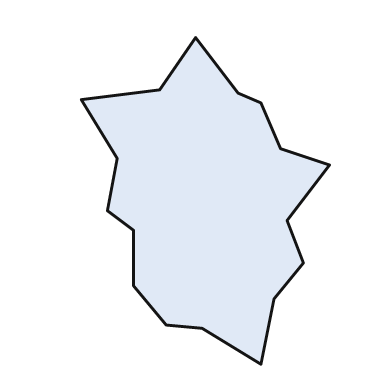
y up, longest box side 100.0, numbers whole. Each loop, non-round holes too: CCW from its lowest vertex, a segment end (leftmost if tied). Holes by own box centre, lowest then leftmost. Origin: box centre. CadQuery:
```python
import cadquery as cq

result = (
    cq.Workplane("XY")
    .moveTo(17.0, -50.0)
    .lineTo(21.0, -30.0)
    .lineTo(30.0, -19.0)
    .lineTo(25.0, -6.0)
    .lineTo(38.0, 11.0)
    .lineTo(23.0, 16.0)
    .lineTo(17.0, 30.0)
    .lineTo(10.0, 33.0)
    .lineTo(-3.0, 50.0)
    .lineTo(-14.0, 34.0)
    .lineTo(-38.0, 31.0)
    .lineTo(-27.0, 13.0)
    .lineTo(-30.0, -3.0)
    .lineTo(-22.0, -9.0)
    .lineTo(-22.0, -26.0)
    .lineTo(-12.0, -38.0)
    .lineTo(-1.0, -39.0)
    .close()
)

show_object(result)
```